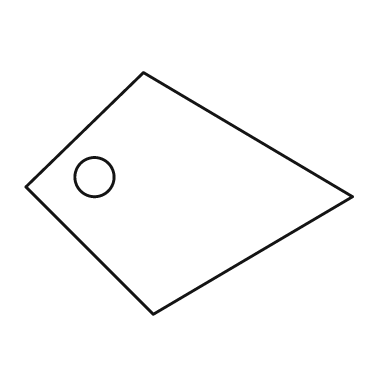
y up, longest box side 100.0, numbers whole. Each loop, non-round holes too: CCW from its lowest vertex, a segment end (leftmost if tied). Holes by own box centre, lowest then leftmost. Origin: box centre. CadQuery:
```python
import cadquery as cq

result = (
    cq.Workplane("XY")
    .moveTo(-11.0, -37.0)
    .lineTo(50.0, -1.0)
    .lineTo(-14.0, 37.0)
    .lineTo(-50.0, 2.0)
    .close()
    .moveTo(-29.0, 5.0)
    .circle(6.0)
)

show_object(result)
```